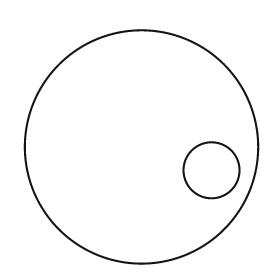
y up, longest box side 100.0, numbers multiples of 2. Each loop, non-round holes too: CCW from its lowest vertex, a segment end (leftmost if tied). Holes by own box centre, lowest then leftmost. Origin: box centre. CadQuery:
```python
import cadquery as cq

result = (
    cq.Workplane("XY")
    .moveTo(0.0, 0.0)
    .circle(50.0)
    .moveTo(30.0, -10.0)
    .circle(12.0)
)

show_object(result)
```